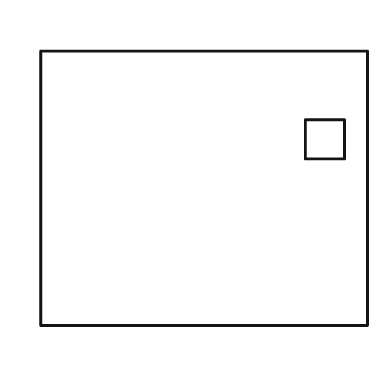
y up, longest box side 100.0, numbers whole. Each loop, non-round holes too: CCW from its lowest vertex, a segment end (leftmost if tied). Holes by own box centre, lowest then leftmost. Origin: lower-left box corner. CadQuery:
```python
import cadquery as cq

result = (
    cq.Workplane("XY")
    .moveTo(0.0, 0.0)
    .lineTo(100.0, 0.0)
    .lineTo(100.0, 84.0)
    .lineTo(0.0, 84.0)
    .close()
    .moveTo(81.0, 51.0)
    .lineTo(93.0, 51.0)
    .lineTo(93.0, 63.0)
    .lineTo(81.0, 63.0)
    .close()
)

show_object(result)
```